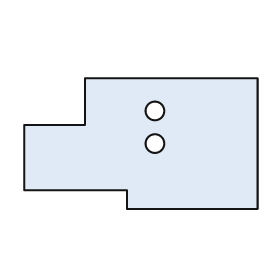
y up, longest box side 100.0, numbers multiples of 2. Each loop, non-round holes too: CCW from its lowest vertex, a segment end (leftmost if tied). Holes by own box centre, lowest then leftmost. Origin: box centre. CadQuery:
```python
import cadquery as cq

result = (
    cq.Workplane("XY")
    .moveTo(-6.0, -28.0)
    .lineTo(50.0, -28.0)
    .lineTo(50.0, 28.0)
    .lineTo(-24.0, 28.0)
    .lineTo(-24.0, 8.0)
    .lineTo(-50.0, 8.0)
    .lineTo(-50.0, -20.0)
    .lineTo(-6.0, -20.0)
    .close()
    .moveTo(6.0, 0.0)
    .circle(4.0)
    .moveTo(6.0, 14.0)
    .circle(4.0)
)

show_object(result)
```